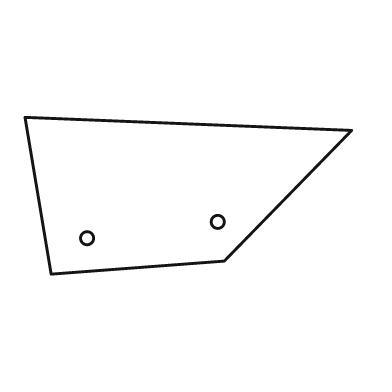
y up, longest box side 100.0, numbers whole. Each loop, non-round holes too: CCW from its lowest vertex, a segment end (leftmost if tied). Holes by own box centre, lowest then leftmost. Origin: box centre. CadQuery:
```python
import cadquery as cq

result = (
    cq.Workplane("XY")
    .moveTo(-42.0, -24.0)
    .lineTo(11.0, -20.0)
    .lineTo(50.0, 20.0)
    .lineTo(-50.0, 24.0)
    .close()
    .moveTo(-31.0, -13.0)
    .circle(2.0)
    .moveTo(9.0, -8.0)
    .circle(2.0)
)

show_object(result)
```